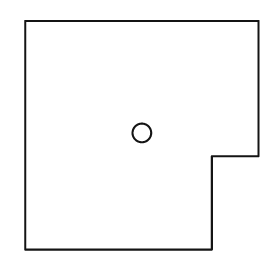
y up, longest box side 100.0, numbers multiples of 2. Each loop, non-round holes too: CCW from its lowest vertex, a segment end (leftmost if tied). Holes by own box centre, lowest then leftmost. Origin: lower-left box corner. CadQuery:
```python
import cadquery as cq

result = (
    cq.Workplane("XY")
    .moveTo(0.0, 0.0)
    .lineTo(80.0, 0.0)
    .lineTo(80.0, 40.0)
    .lineTo(100.0, 40.0)
    .lineTo(100.0, 98.0)
    .lineTo(0.0, 98.0)
    .close()
    .moveTo(50.0, 50.0)
    .circle(4.0)
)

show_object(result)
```